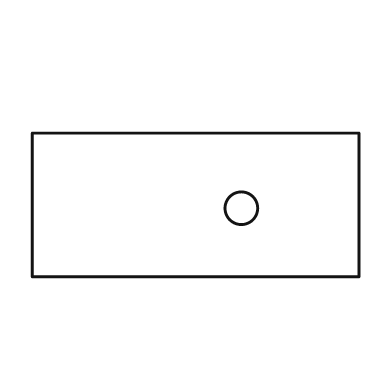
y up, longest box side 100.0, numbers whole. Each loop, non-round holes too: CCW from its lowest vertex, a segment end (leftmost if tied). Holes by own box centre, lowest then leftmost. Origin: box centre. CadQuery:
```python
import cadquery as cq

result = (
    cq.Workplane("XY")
    .moveTo(-50.0, -22.0)
    .lineTo(50.0, -22.0)
    .lineTo(50.0, 22.0)
    .lineTo(-50.0, 22.0)
    .close()
    .moveTo(14.0, -1.0)
    .circle(5.0)
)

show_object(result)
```